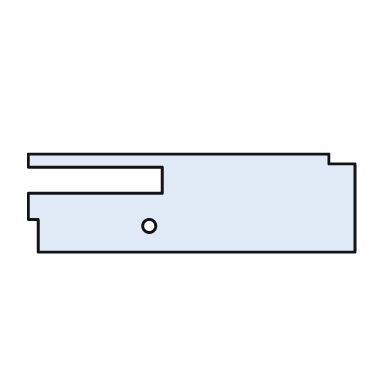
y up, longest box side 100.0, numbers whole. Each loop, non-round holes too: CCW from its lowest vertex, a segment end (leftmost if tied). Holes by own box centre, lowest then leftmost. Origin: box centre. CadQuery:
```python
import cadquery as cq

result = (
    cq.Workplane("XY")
    .moveTo(-47.0, -15.0)
    .lineTo(50.0, -15.0)
    .lineTo(50.0, 12.0)
    .lineTo(42.0, 12.0)
    .lineTo(42.0, 15.0)
    .lineTo(-50.0, 15.0)
    .lineTo(-50.0, 11.0)
    .lineTo(-9.0, 11.0)
    .lineTo(-9.0, 3.0)
    .lineTo(-50.0, 3.0)
    .lineTo(-50.0, -5.0)
    .lineTo(-47.0, -5.0)
    .close()
    .moveTo(-13.0, -7.0)
    .circle(2.0)
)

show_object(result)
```